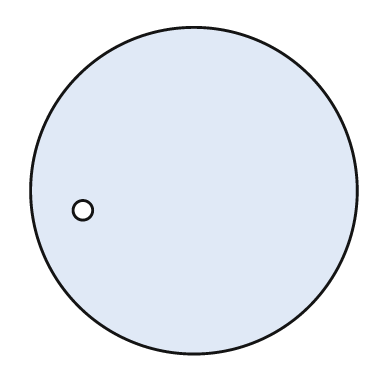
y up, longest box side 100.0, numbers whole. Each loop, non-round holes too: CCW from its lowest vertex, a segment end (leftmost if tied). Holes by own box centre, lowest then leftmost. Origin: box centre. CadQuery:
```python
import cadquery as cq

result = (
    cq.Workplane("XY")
    .moveTo(0.0, 0.0)
    .circle(50.0)
    .moveTo(-34.0, -6.0)
    .circle(3.0)
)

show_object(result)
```